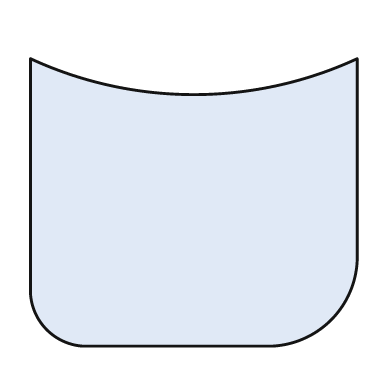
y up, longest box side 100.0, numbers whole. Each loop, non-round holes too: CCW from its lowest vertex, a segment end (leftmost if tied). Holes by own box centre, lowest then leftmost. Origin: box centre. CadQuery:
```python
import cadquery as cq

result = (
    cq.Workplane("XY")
    .moveTo(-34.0, -44.0)
    .lineTo(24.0, -44.0)
    .threePointArc((42.0, -36.0), (50.0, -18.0))
    .lineTo(50.0, 44.0)
    .threePointArc((0.0, 33.0), (-50.0, 44.0))
    .lineTo(-50.0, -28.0)
    .threePointArc((-45.0, -39.0), (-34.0, -44.0))
    .close()
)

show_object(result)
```